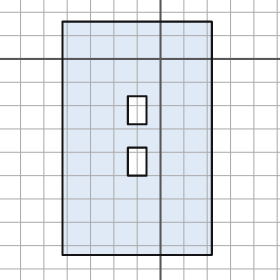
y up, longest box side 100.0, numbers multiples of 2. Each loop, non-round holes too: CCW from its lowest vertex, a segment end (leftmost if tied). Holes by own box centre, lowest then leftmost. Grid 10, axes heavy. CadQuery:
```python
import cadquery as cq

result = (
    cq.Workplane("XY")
    .moveTo(-42.0, -84.0)
    .lineTo(22.0, -84.0)
    .lineTo(22.0, 16.0)
    .lineTo(-42.0, 16.0)
    .close()
    .moveTo(-14.0, -50.0)
    .lineTo(-6.0, -50.0)
    .lineTo(-6.0, -38.0)
    .lineTo(-14.0, -38.0)
    .close()
    .moveTo(-14.0, -28.0)
    .lineTo(-6.0, -28.0)
    .lineTo(-6.0, -16.0)
    .lineTo(-14.0, -16.0)
    .close()
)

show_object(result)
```